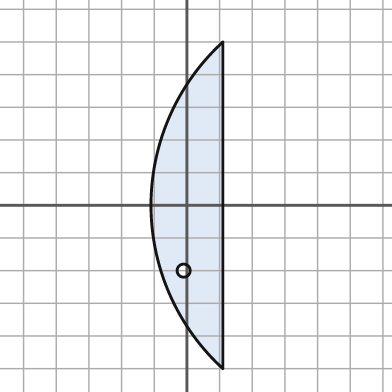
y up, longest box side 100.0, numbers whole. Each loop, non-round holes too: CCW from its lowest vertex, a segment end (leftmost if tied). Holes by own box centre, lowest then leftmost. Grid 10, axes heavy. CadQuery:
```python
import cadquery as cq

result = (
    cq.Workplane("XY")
    .moveTo(11.0, -50.0)
    .lineTo(11.0, 50.0)
    .threePointArc((-11.0, 0.0), (11.0, -50.0))
    .close()
    .moveTo(-1.0, -20.0)
    .circle(2.0)
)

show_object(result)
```